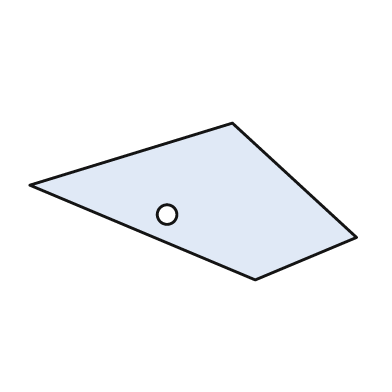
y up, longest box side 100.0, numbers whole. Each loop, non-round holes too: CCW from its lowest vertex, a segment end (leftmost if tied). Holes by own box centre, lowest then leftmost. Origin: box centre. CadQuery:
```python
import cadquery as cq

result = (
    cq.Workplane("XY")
    .moveTo(19.0, -24.0)
    .lineTo(50.0, -11.0)
    .lineTo(12.0, 24.0)
    .lineTo(-50.0, 5.0)
    .close()
    .moveTo(-8.0, -4.0)
    .circle(3.0)
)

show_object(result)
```